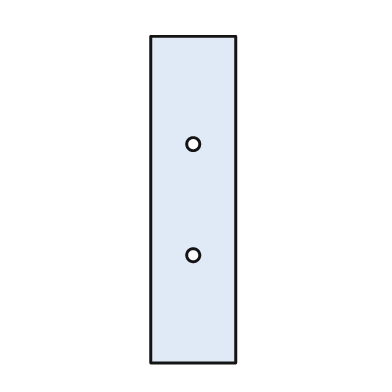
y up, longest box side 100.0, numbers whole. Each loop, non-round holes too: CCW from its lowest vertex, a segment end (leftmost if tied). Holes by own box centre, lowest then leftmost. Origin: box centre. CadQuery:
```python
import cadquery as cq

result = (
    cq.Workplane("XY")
    .moveTo(-13.0, -50.0)
    .lineTo(13.0, -50.0)
    .lineTo(13.0, 50.0)
    .lineTo(-13.0, 50.0)
    .close()
    .moveTo(0.0, -17.0)
    .circle(2.0)
    .moveTo(0.0, 17.0)
    .circle(2.0)
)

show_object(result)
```